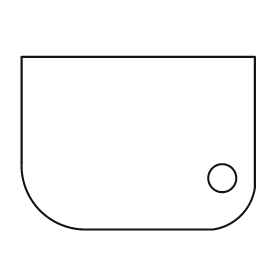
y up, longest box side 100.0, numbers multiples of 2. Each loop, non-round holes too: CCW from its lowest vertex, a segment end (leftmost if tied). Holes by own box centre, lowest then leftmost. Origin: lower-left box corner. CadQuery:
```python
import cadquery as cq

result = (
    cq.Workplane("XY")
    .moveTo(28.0, 0.0)
    .lineTo(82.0, 0.0)
    .threePointArc((94.0, 6.0), (100.0, 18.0))
    .lineTo(100.0, 74.0)
    .lineTo(0.0, 74.0)
    .lineTo(0.0, 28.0)
    .threePointArc((8.0, 8.0), (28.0, 0.0))
    .close()
    .moveTo(86.0, 22.0)
    .circle(6.0)
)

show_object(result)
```